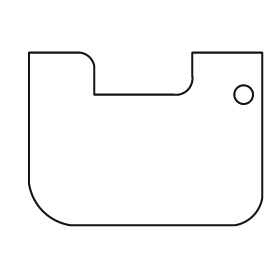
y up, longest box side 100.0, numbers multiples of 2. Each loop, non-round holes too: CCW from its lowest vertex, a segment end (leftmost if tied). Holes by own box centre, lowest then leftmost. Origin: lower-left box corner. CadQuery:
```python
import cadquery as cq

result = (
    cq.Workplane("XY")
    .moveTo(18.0, 0.0)
    .lineTo(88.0, 0.0)
    .threePointArc((96.0, 4.0), (100.0, 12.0))
    .lineTo(100.0, 74.0)
    .lineTo(70.0, 74.0)
    .lineTo(70.0, 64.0)
    .threePointArc((68.0, 58.0), (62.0, 56.0))
    .lineTo(28.0, 56.0)
    .lineTo(28.0, 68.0)
    .threePointArc((26.0, 72.0), (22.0, 74.0))
    .lineTo(0.0, 74.0)
    .lineTo(0.0, 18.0)
    .threePointArc((6.0, 6.0), (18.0, 0.0))
    .close()
    .moveTo(92.0, 56.0)
    .circle(4.0)
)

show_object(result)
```